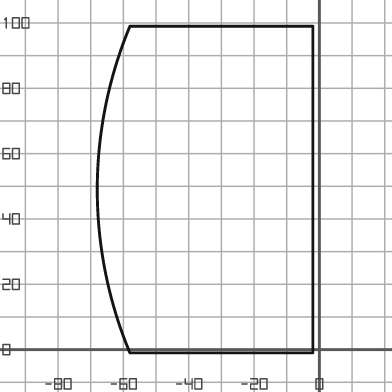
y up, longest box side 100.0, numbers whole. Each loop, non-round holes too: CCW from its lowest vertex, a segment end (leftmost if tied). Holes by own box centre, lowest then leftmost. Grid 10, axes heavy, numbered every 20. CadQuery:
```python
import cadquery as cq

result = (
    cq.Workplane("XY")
    .moveTo(-58.0, -1.0)
    .lineTo(-2.0, -1.0)
    .lineTo(-2.0, 99.0)
    .lineTo(-58.0, 99.0)
    .threePointArc((-68.0, 49.0), (-58.0, -1.0))
    .close()
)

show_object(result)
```